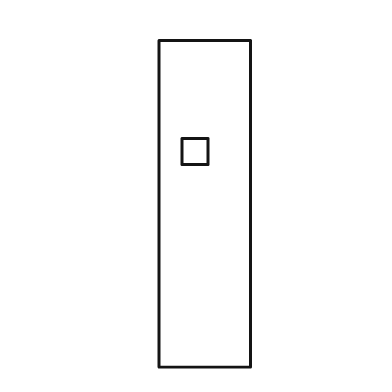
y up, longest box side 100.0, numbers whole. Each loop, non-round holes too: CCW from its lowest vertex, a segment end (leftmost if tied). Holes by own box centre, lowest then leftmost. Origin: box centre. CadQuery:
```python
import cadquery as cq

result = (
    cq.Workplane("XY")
    .moveTo(-14.0, -50.0)
    .lineTo(14.0, -50.0)
    .lineTo(14.0, 50.0)
    .lineTo(-14.0, 50.0)
    .close()
    .moveTo(-7.0, 12.0)
    .lineTo(1.0, 12.0)
    .lineTo(1.0, 20.0)
    .lineTo(-7.0, 20.0)
    .close()
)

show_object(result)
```